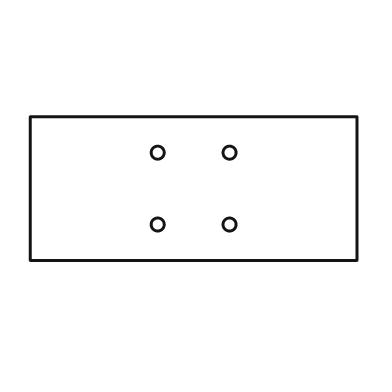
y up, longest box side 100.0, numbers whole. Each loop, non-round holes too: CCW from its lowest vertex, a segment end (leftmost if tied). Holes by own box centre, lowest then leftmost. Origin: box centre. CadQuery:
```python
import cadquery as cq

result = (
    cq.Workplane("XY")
    .moveTo(-50.0, -22.0)
    .lineTo(50.0, -22.0)
    .lineTo(50.0, 22.0)
    .lineTo(-50.0, 22.0)
    .close()
    .moveTo(-11.0, -11.0)
    .circle(2.0)
    .moveTo(11.0, -11.0)
    .circle(2.0)
    .moveTo(-11.0, 11.0)
    .circle(2.0)
    .moveTo(11.0, 11.0)
    .circle(2.0)
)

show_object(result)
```